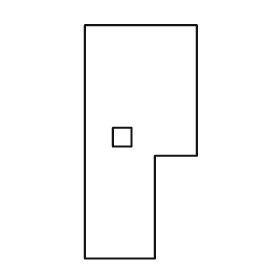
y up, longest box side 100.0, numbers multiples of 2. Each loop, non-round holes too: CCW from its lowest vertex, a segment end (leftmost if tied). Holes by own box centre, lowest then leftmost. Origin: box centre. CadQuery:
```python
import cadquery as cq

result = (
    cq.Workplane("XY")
    .moveTo(-24.0, -50.0)
    .lineTo(6.0, -50.0)
    .lineTo(6.0, -6.0)
    .lineTo(24.0, -6.0)
    .lineTo(24.0, 50.0)
    .lineTo(-24.0, 50.0)
    .close()
    .moveTo(-12.0, -2.0)
    .lineTo(-4.0, -2.0)
    .lineTo(-4.0, 6.0)
    .lineTo(-12.0, 6.0)
    .close()
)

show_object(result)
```